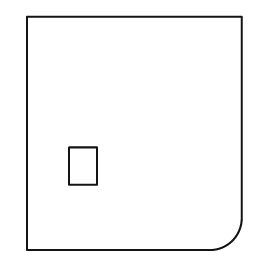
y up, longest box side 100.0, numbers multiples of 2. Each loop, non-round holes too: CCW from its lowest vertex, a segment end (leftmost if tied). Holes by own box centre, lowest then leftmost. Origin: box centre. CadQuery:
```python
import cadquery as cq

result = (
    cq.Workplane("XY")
    .moveTo(-46.0, -50.0)
    .lineTo(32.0, -50.0)
    .threePointArc((42.0, -46.0), (46.0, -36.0))
    .lineTo(46.0, 50.0)
    .lineTo(-46.0, 50.0)
    .close()
    .moveTo(-28.0, -22.0)
    .lineTo(-16.0, -22.0)
    .lineTo(-16.0, -6.0)
    .lineTo(-28.0, -6.0)
    .close()
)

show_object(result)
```